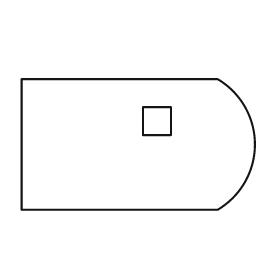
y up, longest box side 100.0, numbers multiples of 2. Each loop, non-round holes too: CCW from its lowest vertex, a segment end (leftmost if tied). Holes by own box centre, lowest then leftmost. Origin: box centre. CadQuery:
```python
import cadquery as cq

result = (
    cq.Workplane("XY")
    .moveTo(-50.0, -28.0)
    .lineTo(34.0, -28.0)
    .threePointArc((50.0, 0.0), (34.0, 28.0))
    .lineTo(-50.0, 28.0)
    .close()
    .moveTo(2.0, 4.0)
    .lineTo(14.0, 4.0)
    .lineTo(14.0, 16.0)
    .lineTo(2.0, 16.0)
    .close()
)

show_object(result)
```